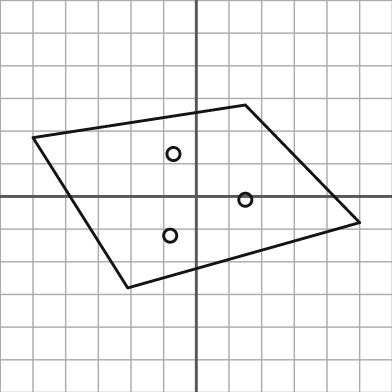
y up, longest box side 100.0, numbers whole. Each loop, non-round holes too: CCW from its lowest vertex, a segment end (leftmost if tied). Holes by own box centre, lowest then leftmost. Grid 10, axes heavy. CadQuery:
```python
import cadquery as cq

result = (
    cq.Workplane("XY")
    .moveTo(-21.0, -28.0)
    .lineTo(50.0, -8.0)
    .lineTo(15.0, 28.0)
    .lineTo(-50.0, 18.0)
    .close()
    .moveTo(-8.0, -12.0)
    .circle(2.0)
    .moveTo(15.0, -1.0)
    .circle(2.0)
    .moveTo(-7.0, 13.0)
    .circle(2.0)
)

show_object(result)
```